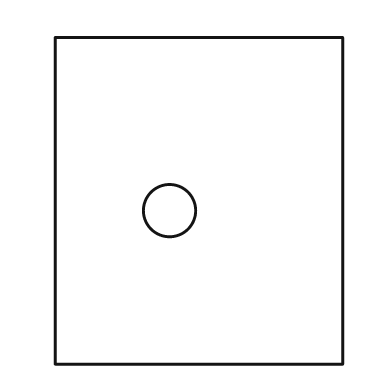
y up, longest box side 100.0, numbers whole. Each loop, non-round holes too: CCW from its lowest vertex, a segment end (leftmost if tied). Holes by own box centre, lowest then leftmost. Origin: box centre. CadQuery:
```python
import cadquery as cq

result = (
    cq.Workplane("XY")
    .moveTo(-44.0, -50.0)
    .lineTo(44.0, -50.0)
    .lineTo(44.0, 50.0)
    .lineTo(-44.0, 50.0)
    .close()
    .moveTo(-9.0, -3.0)
    .circle(8.0)
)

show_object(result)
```